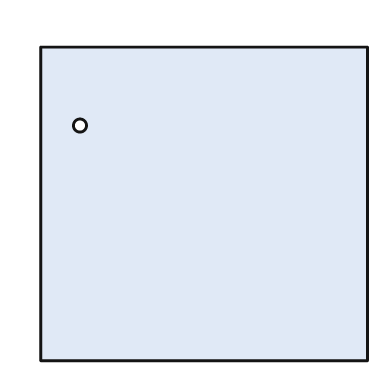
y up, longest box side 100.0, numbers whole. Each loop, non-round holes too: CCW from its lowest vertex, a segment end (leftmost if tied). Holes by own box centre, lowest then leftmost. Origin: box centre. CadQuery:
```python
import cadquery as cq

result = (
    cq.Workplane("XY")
    .moveTo(-50.0, -48.0)
    .lineTo(50.0, -48.0)
    .lineTo(50.0, 48.0)
    .lineTo(-50.0, 48.0)
    .close()
    .moveTo(-38.0, 24.0)
    .circle(2.0)
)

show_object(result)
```